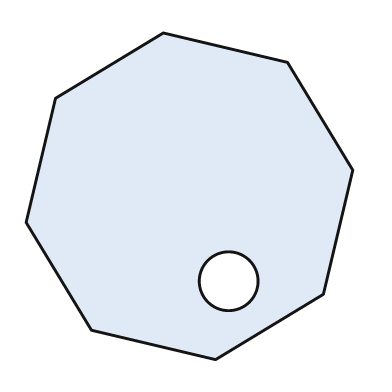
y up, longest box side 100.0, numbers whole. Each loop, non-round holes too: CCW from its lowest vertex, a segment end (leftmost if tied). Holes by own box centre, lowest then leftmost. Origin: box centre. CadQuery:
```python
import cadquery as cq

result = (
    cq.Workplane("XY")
    .moveTo(8.0, -50.0)
    .lineTo(41.0, -30.0)
    .lineTo(50.0, 8.0)
    .lineTo(30.0, 41.0)
    .lineTo(-8.0, 50.0)
    .lineTo(-41.0, 30.0)
    .lineTo(-50.0, -8.0)
    .lineTo(-30.0, -41.0)
    .close()
    .moveTo(12.0, -26.0)
    .circle(9.0)
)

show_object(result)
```